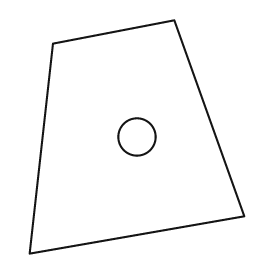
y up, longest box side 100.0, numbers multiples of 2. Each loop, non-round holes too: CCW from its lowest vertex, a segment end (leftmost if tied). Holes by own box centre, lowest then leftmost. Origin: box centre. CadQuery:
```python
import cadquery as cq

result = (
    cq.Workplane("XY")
    .moveTo(-46.0, -50.0)
    .lineTo(46.0, -34.0)
    .lineTo(16.0, 50.0)
    .lineTo(-36.0, 40.0)
    .close()
    .moveTo(0.0, 0.0)
    .circle(8.0)
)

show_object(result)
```